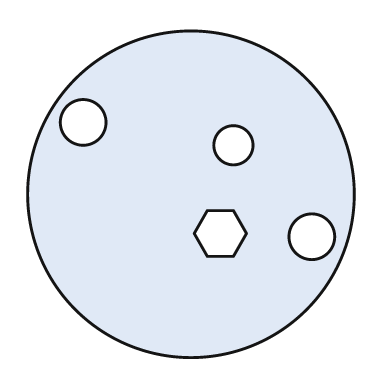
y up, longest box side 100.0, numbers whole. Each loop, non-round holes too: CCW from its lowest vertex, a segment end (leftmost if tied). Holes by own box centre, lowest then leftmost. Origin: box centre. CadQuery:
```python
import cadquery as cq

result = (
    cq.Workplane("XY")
    .moveTo(0.0, 0.0)
    .circle(50.0)
    .moveTo(37.0, -13.0)
    .circle(7.0)
    .moveTo(5.0, -19.0)
    .lineTo(13.0, -19.0)
    .lineTo(17.0, -12.0)
    .lineTo(13.0, -5.0)
    .lineTo(5.0, -5.0)
    .lineTo(1.0, -12.0)
    .close()
    .moveTo(13.0, 15.0)
    .circle(6.0)
    .moveTo(-33.0, 22.0)
    .circle(7.0)
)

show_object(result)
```